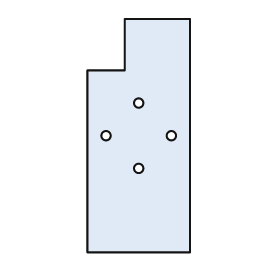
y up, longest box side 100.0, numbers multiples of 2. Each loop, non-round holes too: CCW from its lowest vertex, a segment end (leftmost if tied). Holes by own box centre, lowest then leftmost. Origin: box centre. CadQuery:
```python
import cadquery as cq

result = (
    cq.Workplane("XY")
    .moveTo(-22.0, -50.0)
    .lineTo(22.0, -50.0)
    .lineTo(22.0, 50.0)
    .lineTo(-6.0, 50.0)
    .lineTo(-6.0, 28.0)
    .lineTo(-22.0, 28.0)
    .close()
    .moveTo(0.0, -14.0)
    .circle(2.0)
    .moveTo(-14.0, 0.0)
    .circle(2.0)
    .moveTo(14.0, 0.0)
    .circle(2.0)
    .moveTo(0.0, 14.0)
    .circle(2.0)
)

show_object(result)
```